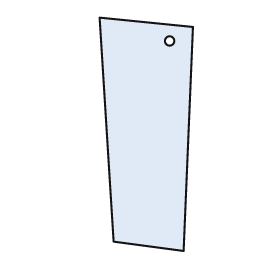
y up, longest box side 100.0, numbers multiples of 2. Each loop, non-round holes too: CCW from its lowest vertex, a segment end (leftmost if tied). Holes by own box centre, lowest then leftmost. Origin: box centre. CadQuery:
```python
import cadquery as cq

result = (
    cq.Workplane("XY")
    .moveTo(16.0, -50.0)
    .lineTo(20.0, 46.0)
    .lineTo(-20.0, 50.0)
    .lineTo(-14.0, -46.0)
    .close()
    .moveTo(10.0, 40.0)
    .circle(2.0)
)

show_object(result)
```